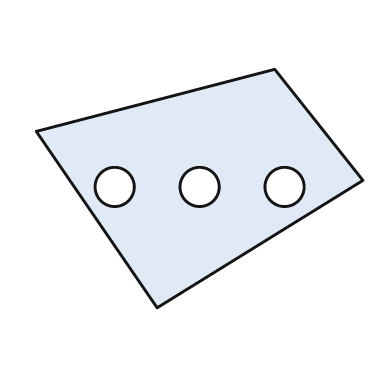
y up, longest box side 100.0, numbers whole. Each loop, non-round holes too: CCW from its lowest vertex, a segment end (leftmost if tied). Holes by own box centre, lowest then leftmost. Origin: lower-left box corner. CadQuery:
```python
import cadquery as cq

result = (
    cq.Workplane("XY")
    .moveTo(37.0, 0.0)
    .lineTo(100.0, 39.0)
    .lineTo(73.0, 73.0)
    .lineTo(0.0, 54.0)
    .close()
    .moveTo(24.0, 37.0)
    .circle(6.0)
    .moveTo(50.0, 37.0)
    .circle(6.0)
    .moveTo(76.0, 37.0)
    .circle(6.0)
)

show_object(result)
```